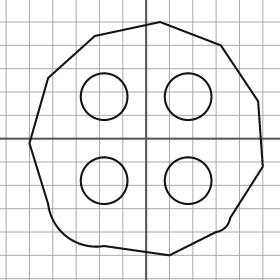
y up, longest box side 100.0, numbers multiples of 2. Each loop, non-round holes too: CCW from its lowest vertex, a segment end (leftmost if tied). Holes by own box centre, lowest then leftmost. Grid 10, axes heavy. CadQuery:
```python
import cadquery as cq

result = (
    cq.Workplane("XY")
    .moveTo(10.0, -50.0)
    .lineTo(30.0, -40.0)
    .threePointArc((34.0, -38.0), (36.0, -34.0))
    .lineTo(50.0, -12.0)
    .lineTo(48.0, 16.0)
    .lineTo(32.0, 40.0)
    .lineTo(6.0, 50.0)
    .lineTo(-22.0, 44.0)
    .lineTo(-42.0, 26.0)
    .lineTo(-50.0, -2.0)
    .lineTo(-42.0, -28.0)
    .threePointArc((-34.0, -42.0), (-18.0, -46.0))
    .close()
    .moveTo(-18.0, -18.0)
    .circle(10.0)
    .moveTo(18.0, -18.0)
    .circle(10.0)
    .moveTo(-18.0, 18.0)
    .circle(10.0)
    .moveTo(18.0, 18.0)
    .circle(10.0)
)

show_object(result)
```